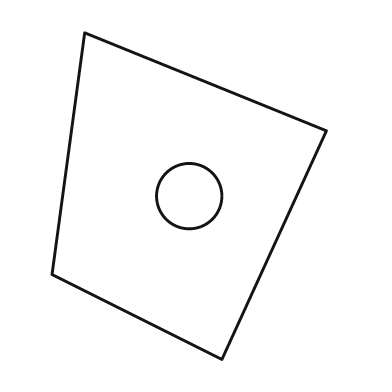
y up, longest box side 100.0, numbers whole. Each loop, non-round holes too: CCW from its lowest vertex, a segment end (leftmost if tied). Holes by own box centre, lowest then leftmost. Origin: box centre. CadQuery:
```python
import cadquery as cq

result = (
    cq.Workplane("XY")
    .moveTo(10.0, -50.0)
    .lineTo(42.0, 20.0)
    .lineTo(-32.0, 50.0)
    .lineTo(-42.0, -24.0)
    .close()
    .moveTo(0.0, 0.0)
    .circle(10.0)
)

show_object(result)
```